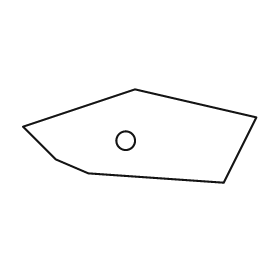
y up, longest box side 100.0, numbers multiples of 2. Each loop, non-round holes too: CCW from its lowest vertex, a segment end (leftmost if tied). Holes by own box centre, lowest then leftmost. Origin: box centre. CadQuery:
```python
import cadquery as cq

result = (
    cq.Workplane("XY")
    .moveTo(36.0, -20.0)
    .lineTo(50.0, 8.0)
    .lineTo(-2.0, 20.0)
    .lineTo(-50.0, 4.0)
    .lineTo(-36.0, -10.0)
    .lineTo(-22.0, -16.0)
    .close()
    .moveTo(-6.0, -2.0)
    .circle(4.0)
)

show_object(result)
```